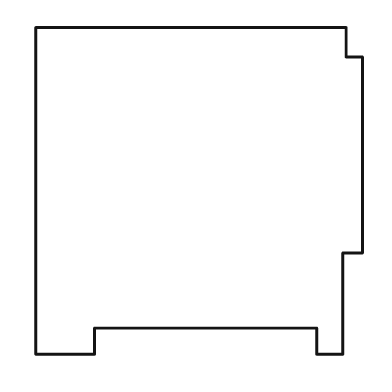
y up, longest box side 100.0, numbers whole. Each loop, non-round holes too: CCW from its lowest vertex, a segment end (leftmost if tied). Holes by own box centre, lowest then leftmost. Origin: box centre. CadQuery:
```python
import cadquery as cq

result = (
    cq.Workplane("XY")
    .moveTo(-50.0, -50.0)
    .lineTo(-32.0, -50.0)
    .lineTo(-32.0, -42.0)
    .lineTo(36.0, -42.0)
    .lineTo(36.0, -50.0)
    .lineTo(44.0, -50.0)
    .lineTo(44.0, -19.0)
    .lineTo(50.0, -19.0)
    .lineTo(50.0, 41.0)
    .lineTo(45.0, 41.0)
    .lineTo(45.0, 50.0)
    .lineTo(-50.0, 50.0)
    .close()
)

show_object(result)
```